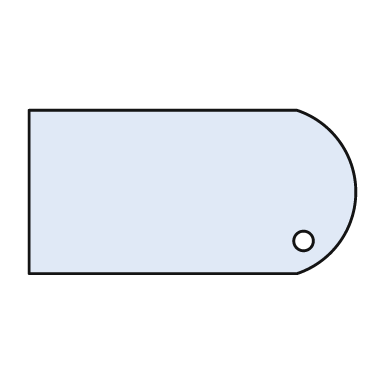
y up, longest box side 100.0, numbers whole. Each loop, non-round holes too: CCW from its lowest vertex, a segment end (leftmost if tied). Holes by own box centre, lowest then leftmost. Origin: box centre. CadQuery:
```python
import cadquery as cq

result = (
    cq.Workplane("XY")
    .moveTo(-50.0, -25.0)
    .lineTo(32.0, -25.0)
    .threePointArc((50.0, 0.0), (32.0, 25.0))
    .lineTo(-50.0, 25.0)
    .close()
    .moveTo(34.0, -15.0)
    .circle(3.0)
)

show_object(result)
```